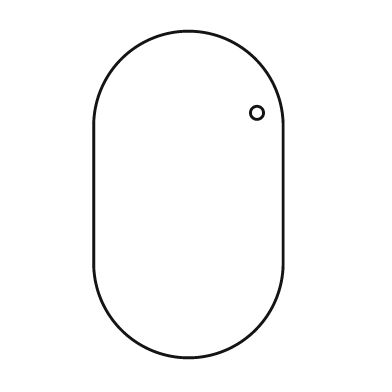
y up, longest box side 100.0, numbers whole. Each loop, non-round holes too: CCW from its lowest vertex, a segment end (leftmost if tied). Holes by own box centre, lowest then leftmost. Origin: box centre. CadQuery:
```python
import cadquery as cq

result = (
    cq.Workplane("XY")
    .moveTo(-29.0, -21.0)
    .threePointArc((0.0, -50.0), (29.0, -21.0))
    .lineTo(29.0, 21.0)
    .threePointArc((0.0, 50.0), (-29.0, 21.0))
    .close()
    .moveTo(21.0, 25.0)
    .circle(2.0)
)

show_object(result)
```